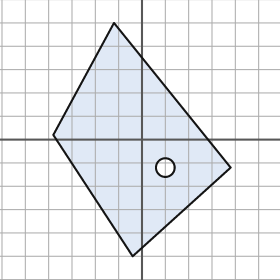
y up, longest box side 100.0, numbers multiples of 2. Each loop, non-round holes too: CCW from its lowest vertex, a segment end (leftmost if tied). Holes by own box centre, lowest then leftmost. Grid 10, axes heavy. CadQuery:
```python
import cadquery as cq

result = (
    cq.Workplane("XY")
    .moveTo(-4.0, -50.0)
    .lineTo(38.0, -12.0)
    .lineTo(-12.0, 50.0)
    .lineTo(-38.0, 2.0)
    .close()
    .moveTo(10.0, -12.0)
    .circle(4.0)
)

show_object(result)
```